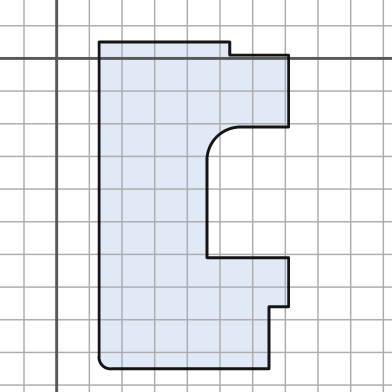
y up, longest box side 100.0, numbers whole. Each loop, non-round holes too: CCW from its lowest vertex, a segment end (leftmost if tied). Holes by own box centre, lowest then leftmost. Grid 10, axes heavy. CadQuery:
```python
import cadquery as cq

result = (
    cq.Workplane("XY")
    .moveTo(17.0, -95.0)
    .lineTo(65.0, -95.0)
    .lineTo(65.0, -76.0)
    .lineTo(71.0, -76.0)
    .lineTo(71.0, -61.0)
    .lineTo(46.0, -61.0)
    .lineTo(46.0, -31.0)
    .threePointArc((49.0, -24.0), (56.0, -21.0))
    .lineTo(71.0, -21.0)
    .lineTo(71.0, 1.0)
    .lineTo(53.0, 1.0)
    .lineTo(53.0, 5.0)
    .lineTo(13.0, 5.0)
    .lineTo(13.0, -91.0)
    .threePointArc((14.0, -94.0), (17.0, -95.0))
    .close()
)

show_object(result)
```